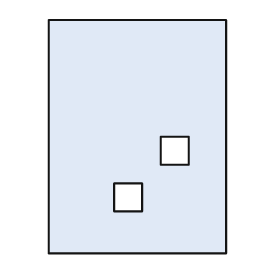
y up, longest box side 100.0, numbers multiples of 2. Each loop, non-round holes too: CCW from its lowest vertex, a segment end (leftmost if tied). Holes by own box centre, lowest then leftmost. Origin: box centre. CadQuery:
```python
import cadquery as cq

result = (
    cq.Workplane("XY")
    .moveTo(-38.0, -50.0)
    .lineTo(38.0, -50.0)
    .lineTo(38.0, 50.0)
    .lineTo(-38.0, 50.0)
    .close()
    .moveTo(-10.0, -32.0)
    .lineTo(2.0, -32.0)
    .lineTo(2.0, -20.0)
    .lineTo(-10.0, -20.0)
    .close()
    .moveTo(10.0, -12.0)
    .lineTo(22.0, -12.0)
    .lineTo(22.0, 0.0)
    .lineTo(10.0, 0.0)
    .close()
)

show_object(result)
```